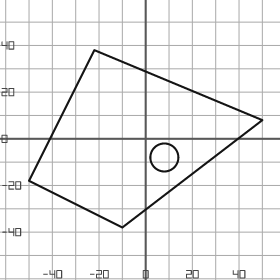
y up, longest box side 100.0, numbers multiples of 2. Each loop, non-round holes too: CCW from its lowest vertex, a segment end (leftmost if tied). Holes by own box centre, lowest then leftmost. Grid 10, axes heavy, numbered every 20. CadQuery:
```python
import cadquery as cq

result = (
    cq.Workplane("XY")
    .moveTo(-10.0, -38.0)
    .lineTo(50.0, 8.0)
    .lineTo(-22.0, 38.0)
    .lineTo(-50.0, -18.0)
    .close()
    .moveTo(8.0, -8.0)
    .circle(6.0)
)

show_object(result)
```